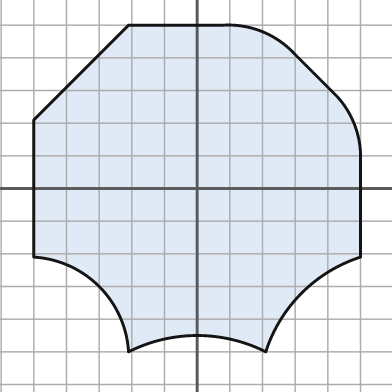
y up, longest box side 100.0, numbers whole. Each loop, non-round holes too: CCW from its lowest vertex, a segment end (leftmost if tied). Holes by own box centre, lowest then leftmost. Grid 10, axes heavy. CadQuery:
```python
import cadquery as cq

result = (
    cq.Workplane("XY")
    .moveTo(-21.0, -50.0)
    .threePointArc((0.0, -45.0), (21.0, -50.0))
    .threePointArc((32.0, -32.0), (50.0, -21.0))
    .lineTo(50.0, 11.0)
    .threePointArc((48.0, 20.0), (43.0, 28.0))
    .lineTo(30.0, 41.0)
    .threePointArc((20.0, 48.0), (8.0, 50.0))
    .lineTo(-21.0, 50.0)
    .lineTo(-50.0, 21.0)
    .lineTo(-50.0, -21.0)
    .threePointArc((-30.0, -30.0), (-21.0, -50.0))
    .close()
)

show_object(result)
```